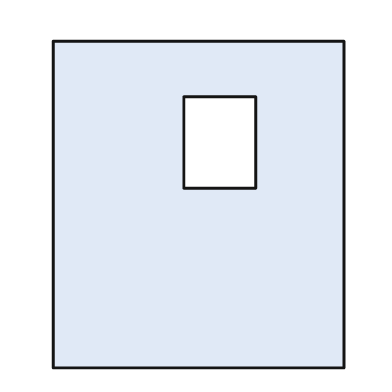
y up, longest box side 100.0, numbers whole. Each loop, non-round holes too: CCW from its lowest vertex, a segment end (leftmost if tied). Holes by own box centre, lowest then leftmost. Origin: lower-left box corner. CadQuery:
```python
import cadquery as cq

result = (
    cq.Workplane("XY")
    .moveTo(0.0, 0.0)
    .lineTo(89.0, 0.0)
    .lineTo(89.0, 100.0)
    .lineTo(0.0, 100.0)
    .close()
    .moveTo(40.0, 55.0)
    .lineTo(62.0, 55.0)
    .lineTo(62.0, 83.0)
    .lineTo(40.0, 83.0)
    .close()
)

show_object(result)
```